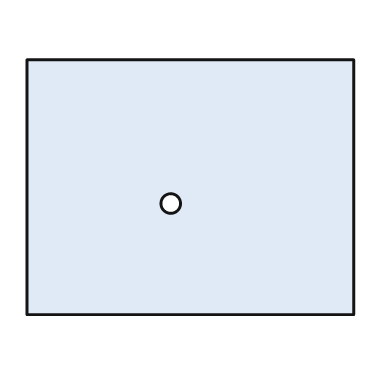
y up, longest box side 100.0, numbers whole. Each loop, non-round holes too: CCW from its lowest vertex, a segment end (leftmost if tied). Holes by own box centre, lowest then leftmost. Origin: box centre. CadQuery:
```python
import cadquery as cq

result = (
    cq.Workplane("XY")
    .moveTo(-50.0, -39.0)
    .lineTo(50.0, -39.0)
    .lineTo(50.0, 39.0)
    .lineTo(-50.0, 39.0)
    .close()
    .moveTo(-6.0, -5.0)
    .circle(3.0)
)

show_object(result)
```